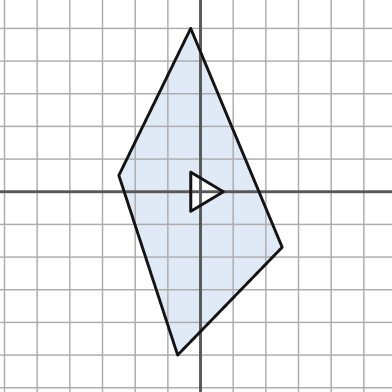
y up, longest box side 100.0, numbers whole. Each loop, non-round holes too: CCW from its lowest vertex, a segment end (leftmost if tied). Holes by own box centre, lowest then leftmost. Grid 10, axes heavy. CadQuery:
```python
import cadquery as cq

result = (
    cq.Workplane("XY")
    .moveTo(-7.0, -50.0)
    .lineTo(25.0, -17.0)
    .lineTo(-3.0, 50.0)
    .lineTo(-25.0, 5.0)
    .close()
    .moveTo(-3.0, -6.0)
    .lineTo(7.0, 0.0)
    .lineTo(-3.0, 6.0)
    .close()
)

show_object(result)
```